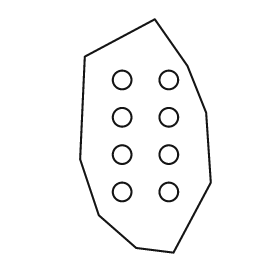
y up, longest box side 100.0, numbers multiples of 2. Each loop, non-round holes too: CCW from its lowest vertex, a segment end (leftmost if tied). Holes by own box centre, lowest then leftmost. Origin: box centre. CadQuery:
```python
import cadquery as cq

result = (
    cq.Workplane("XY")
    .moveTo(12.0, -50.0)
    .lineTo(28.0, -20.0)
    .lineTo(26.0, 10.0)
    .lineTo(18.0, 30.0)
    .lineTo(4.0, 50.0)
    .lineTo(-26.0, 34.0)
    .lineTo(-28.0, -10.0)
    .lineTo(-20.0, -34.0)
    .lineTo(-4.0, -48.0)
    .close()
    .moveTo(-10.0, -24.0)
    .circle(4.0)
    .moveTo(10.0, -24.0)
    .circle(4.0)
    .moveTo(-10.0, -8.0)
    .circle(4.0)
    .moveTo(10.0, -8.0)
    .circle(4.0)
    .moveTo(-10.0, 8.0)
    .circle(4.0)
    .moveTo(10.0, 8.0)
    .circle(4.0)
    .moveTo(-10.0, 24.0)
    .circle(4.0)
    .moveTo(10.0, 24.0)
    .circle(4.0)
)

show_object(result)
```